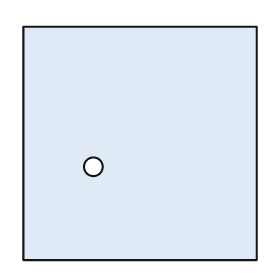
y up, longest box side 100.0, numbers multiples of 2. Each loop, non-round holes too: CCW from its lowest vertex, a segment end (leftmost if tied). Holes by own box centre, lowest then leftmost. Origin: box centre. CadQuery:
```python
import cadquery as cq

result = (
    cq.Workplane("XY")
    .moveTo(-50.0, -50.0)
    .lineTo(50.0, -50.0)
    .lineTo(50.0, 50.0)
    .lineTo(-50.0, 50.0)
    .close()
    .moveTo(-20.0, -10.0)
    .circle(4.0)
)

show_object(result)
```